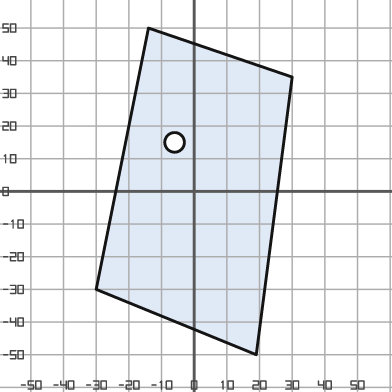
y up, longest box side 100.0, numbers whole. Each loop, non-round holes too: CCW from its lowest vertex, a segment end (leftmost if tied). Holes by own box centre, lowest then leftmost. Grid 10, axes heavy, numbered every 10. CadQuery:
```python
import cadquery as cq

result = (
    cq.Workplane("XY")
    .moveTo(19.0, -50.0)
    .lineTo(30.0, 35.0)
    .lineTo(-14.0, 50.0)
    .lineTo(-30.0, -30.0)
    .close()
    .moveTo(-6.0, 15.0)
    .circle(3.0)
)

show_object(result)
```